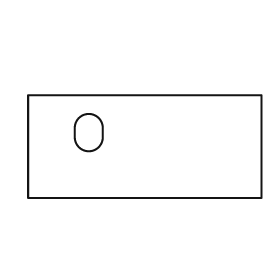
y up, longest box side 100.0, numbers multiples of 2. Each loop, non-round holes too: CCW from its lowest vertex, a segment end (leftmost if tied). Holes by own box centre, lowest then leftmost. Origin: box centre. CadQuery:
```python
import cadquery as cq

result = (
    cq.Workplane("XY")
    .moveTo(-50.0, -22.0)
    .lineTo(50.0, -22.0)
    .lineTo(50.0, 22.0)
    .lineTo(-50.0, 22.0)
    .close()
    .moveTo(-30.0, 4.0)
    .threePointArc((-24.0, -2.0), (-18.0, 4.0))
    .lineTo(-18.0, 8.0)
    .threePointArc((-24.0, 14.0), (-30.0, 8.0))
    .close()
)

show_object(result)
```